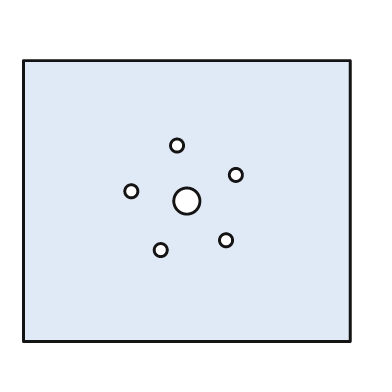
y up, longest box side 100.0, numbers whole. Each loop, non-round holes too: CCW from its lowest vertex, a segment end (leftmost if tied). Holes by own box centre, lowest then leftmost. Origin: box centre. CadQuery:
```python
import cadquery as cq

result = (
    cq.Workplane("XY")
    .moveTo(-50.0, -43.0)
    .lineTo(50.0, -43.0)
    .lineTo(50.0, 43.0)
    .lineTo(-50.0, 43.0)
    .close()
    .moveTo(-8.0, -15.0)
    .circle(2.0)
    .moveTo(12.0, -12.0)
    .circle(2.0)
    .moveTo(0.0, 0.0)
    .circle(4.0)
    .moveTo(-17.0, 3.0)
    .circle(2.0)
    .moveTo(15.0, 8.0)
    .circle(2.0)
    .moveTo(-3.0, 17.0)
    .circle(2.0)
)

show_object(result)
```